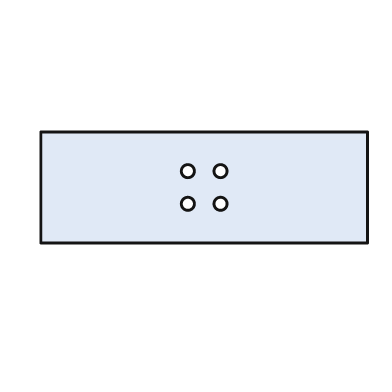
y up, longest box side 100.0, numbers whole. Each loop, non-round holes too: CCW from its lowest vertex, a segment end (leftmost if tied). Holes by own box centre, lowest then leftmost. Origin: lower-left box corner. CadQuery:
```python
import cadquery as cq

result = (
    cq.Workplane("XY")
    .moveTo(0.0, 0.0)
    .lineTo(100.0, 0.0)
    .lineTo(100.0, 34.0)
    .lineTo(0.0, 34.0)
    .close()
    .moveTo(45.0, 12.0)
    .circle(2.0)
    .moveTo(55.0, 12.0)
    .circle(2.0)
    .moveTo(45.0, 22.0)
    .circle(2.0)
    .moveTo(55.0, 22.0)
    .circle(2.0)
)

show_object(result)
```